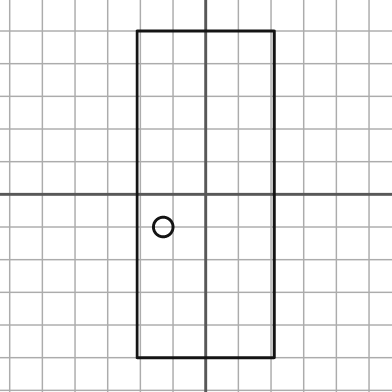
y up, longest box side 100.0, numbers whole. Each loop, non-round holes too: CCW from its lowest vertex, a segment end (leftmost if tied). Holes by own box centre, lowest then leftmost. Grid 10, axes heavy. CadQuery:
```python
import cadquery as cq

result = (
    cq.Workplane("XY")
    .moveTo(-21.0, -50.0)
    .lineTo(21.0, -50.0)
    .lineTo(21.0, 50.0)
    .lineTo(-21.0, 50.0)
    .close()
    .moveTo(-13.0, -10.0)
    .circle(3.0)
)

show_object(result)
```